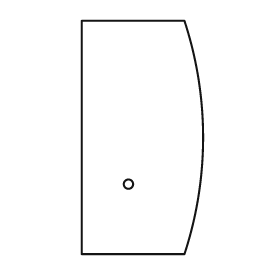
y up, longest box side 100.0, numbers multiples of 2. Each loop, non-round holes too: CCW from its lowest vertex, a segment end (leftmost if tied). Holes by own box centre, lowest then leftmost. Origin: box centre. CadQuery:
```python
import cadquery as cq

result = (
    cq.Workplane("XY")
    .moveTo(-26.0, -50.0)
    .lineTo(18.0, -50.0)
    .threePointArc((26.0, 0.0), (18.0, 50.0))
    .lineTo(-26.0, 50.0)
    .close()
    .moveTo(-6.0, -20.0)
    .circle(2.0)
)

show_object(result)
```